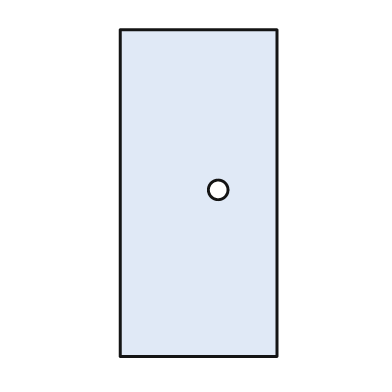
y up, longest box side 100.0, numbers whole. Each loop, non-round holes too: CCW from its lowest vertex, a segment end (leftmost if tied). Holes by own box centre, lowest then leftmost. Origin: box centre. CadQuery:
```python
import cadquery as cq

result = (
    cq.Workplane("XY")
    .moveTo(-24.0, -50.0)
    .lineTo(24.0, -50.0)
    .lineTo(24.0, 50.0)
    .lineTo(-24.0, 50.0)
    .close()
    .moveTo(6.0, 1.0)
    .circle(3.0)
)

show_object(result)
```